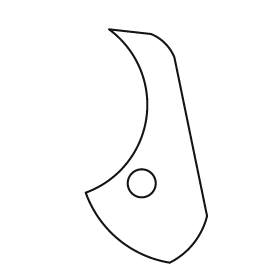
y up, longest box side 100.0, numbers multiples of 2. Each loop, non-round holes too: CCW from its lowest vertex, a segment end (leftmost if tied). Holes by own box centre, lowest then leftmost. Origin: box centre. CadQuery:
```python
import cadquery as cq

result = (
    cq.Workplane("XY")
    .moveTo(10.0, -50.0)
    .threePointArc((20.0, -42.0), (26.0, -30.0))
    .lineTo(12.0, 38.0)
    .threePointArc((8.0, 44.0), (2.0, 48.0))
    .lineTo(-16.0, 50.0)
    .threePointArc((0.0, 12.0), (-26.0, -20.0))
    .threePointArc((-12.0, -40.0), (10.0, -50.0))
    .close()
    .moveTo(-2.0, -16.0)
    .circle(6.0)
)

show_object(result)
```